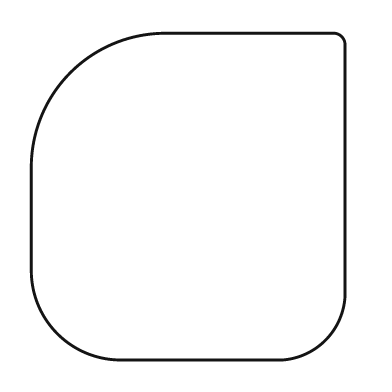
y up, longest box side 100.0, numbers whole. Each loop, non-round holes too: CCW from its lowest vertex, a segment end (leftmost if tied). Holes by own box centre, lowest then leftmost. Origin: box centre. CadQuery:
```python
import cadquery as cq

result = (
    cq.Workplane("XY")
    .moveTo(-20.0, -50.0)
    .lineTo(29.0, -50.0)
    .threePointArc((42.0, -44.0), (48.0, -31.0))
    .lineTo(48.0, 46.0)
    .threePointArc((47.0, 49.0), (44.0, 50.0))
    .lineTo(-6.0, 50.0)
    .threePointArc((-36.0, 38.0), (-48.0, 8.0))
    .lineTo(-48.0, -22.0)
    .threePointArc((-40.0, -42.0), (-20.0, -50.0))
    .close()
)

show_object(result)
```